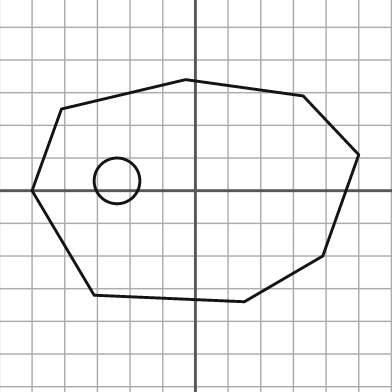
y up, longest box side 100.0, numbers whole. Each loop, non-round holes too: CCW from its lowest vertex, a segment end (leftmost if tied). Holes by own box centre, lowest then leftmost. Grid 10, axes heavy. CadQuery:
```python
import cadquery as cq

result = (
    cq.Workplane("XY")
    .moveTo(15.0, -34.0)
    .lineTo(39.0, -20.0)
    .lineTo(50.0, 11.0)
    .lineTo(33.0, 29.0)
    .lineTo(-3.0, 34.0)
    .lineTo(-41.0, 25.0)
    .lineTo(-50.0, 0.0)
    .lineTo(-31.0, -32.0)
    .close()
    .moveTo(-24.0, 3.0)
    .circle(7.0)
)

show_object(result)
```